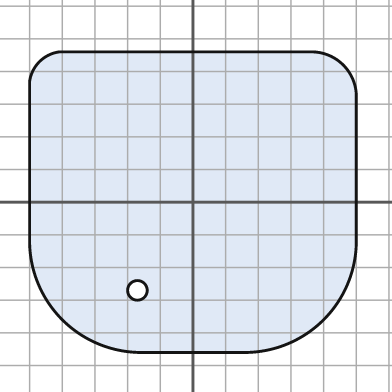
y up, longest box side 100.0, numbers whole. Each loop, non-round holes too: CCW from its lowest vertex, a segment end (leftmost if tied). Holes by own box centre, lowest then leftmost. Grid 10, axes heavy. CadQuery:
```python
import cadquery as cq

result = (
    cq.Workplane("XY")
    .moveTo(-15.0, -46.0)
    .lineTo(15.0, -46.0)
    .threePointArc((40.0, -36.0), (50.0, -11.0))
    .lineTo(50.0, 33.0)
    .threePointArc((46.0, 42.0), (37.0, 46.0))
    .lineTo(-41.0, 46.0)
    .threePointArc((-47.0, 43.0), (-50.0, 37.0))
    .lineTo(-50.0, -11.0)
    .threePointArc((-40.0, -36.0), (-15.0, -46.0))
    .close()
    .moveTo(-17.0, -27.0)
    .circle(3.0)
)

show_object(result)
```